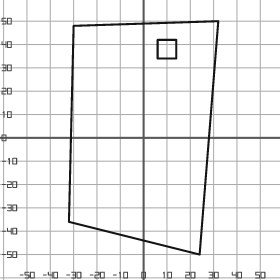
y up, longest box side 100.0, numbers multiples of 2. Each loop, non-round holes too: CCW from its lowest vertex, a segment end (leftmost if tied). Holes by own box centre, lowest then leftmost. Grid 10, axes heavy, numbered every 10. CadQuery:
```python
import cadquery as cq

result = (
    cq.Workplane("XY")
    .moveTo(24.0, -50.0)
    .lineTo(32.0, 50.0)
    .lineTo(-30.0, 48.0)
    .lineTo(-32.0, -36.0)
    .close()
    .moveTo(6.0, 34.0)
    .lineTo(14.0, 34.0)
    .lineTo(14.0, 42.0)
    .lineTo(6.0, 42.0)
    .close()
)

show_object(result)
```